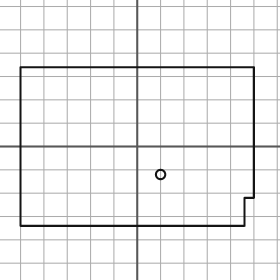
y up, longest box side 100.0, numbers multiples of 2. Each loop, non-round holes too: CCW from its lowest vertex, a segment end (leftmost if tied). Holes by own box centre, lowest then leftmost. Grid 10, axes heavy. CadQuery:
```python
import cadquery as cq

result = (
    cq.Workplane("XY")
    .moveTo(-50.0, -34.0)
    .lineTo(46.0, -34.0)
    .lineTo(46.0, -22.0)
    .lineTo(50.0, -22.0)
    .lineTo(50.0, 34.0)
    .lineTo(-50.0, 34.0)
    .close()
    .moveTo(10.0, -12.0)
    .circle(2.0)
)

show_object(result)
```